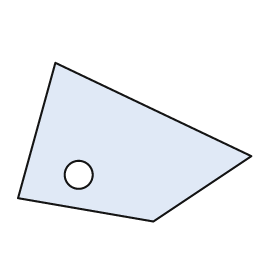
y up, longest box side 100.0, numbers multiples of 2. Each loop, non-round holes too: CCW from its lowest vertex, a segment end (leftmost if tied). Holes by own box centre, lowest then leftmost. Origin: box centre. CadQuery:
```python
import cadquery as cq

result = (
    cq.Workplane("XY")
    .moveTo(8.0, -34.0)
    .lineTo(50.0, -6.0)
    .lineTo(-34.0, 34.0)
    .lineTo(-50.0, -24.0)
    .close()
    .moveTo(-24.0, -14.0)
    .circle(6.0)
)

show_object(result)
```